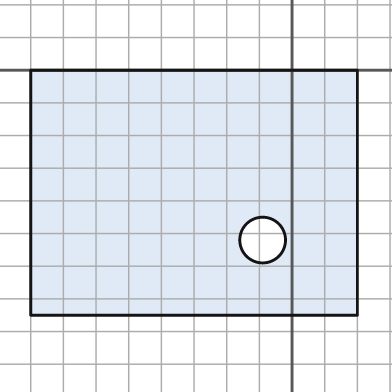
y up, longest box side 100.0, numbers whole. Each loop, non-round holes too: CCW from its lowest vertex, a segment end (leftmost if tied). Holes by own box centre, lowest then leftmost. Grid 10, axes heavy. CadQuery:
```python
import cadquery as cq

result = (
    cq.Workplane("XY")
    .moveTo(-80.0, -75.0)
    .lineTo(20.0, -75.0)
    .lineTo(20.0, 0.0)
    .lineTo(-80.0, 0.0)
    .close()
    .moveTo(-9.0, -52.0)
    .circle(7.0)
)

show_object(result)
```